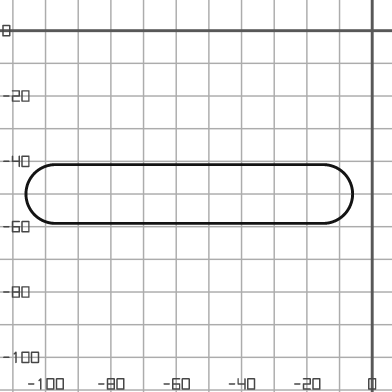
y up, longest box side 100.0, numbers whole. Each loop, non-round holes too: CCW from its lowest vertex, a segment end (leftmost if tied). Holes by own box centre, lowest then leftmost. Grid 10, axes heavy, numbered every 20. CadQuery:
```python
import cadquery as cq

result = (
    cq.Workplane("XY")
    .moveTo(-97.0, -59.0)
    .lineTo(-15.0, -59.0)
    .threePointArc((-6.0, -50.0), (-15.0, -41.0))
    .lineTo(-97.0, -41.0)
    .threePointArc((-106.0, -50.0), (-97.0, -59.0))
    .close()
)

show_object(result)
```